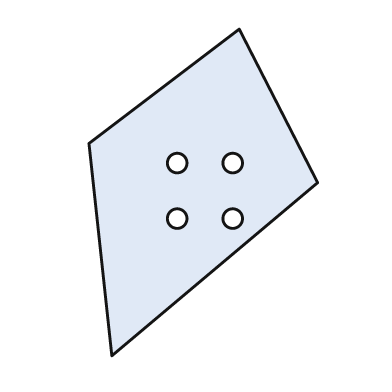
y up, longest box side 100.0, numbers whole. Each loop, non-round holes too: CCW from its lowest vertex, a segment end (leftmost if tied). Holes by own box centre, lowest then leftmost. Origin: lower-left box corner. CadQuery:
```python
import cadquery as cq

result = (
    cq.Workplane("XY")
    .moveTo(7.0, 0.0)
    .lineTo(70.0, 53.0)
    .lineTo(46.0, 100.0)
    .lineTo(0.0, 65.0)
    .close()
    .moveTo(27.0, 42.0)
    .circle(3.0)
    .moveTo(44.0, 42.0)
    .circle(3.0)
    .moveTo(27.0, 59.0)
    .circle(3.0)
    .moveTo(44.0, 59.0)
    .circle(3.0)
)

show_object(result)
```